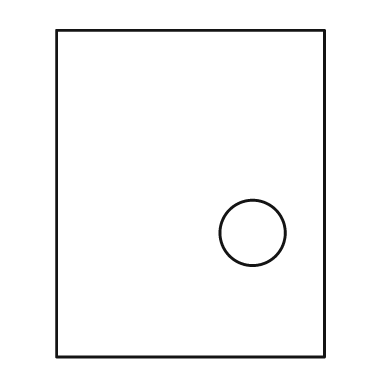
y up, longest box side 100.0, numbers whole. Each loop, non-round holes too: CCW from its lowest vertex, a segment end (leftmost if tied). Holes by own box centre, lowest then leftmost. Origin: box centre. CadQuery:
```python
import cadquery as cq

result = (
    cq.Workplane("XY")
    .moveTo(-41.0, -50.0)
    .lineTo(41.0, -50.0)
    .lineTo(41.0, 50.0)
    .lineTo(-41.0, 50.0)
    .close()
    .moveTo(19.0, -12.0)
    .circle(10.0)
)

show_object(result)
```